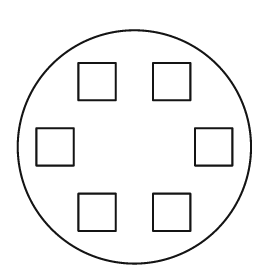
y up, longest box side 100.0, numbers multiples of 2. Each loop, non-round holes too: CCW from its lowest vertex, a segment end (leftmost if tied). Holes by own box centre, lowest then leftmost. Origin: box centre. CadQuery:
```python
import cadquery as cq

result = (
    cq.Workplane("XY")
    .moveTo(0.0, 0.0)
    .circle(50.0)
    .moveTo(-24.0, -36.0)
    .lineTo(-8.0, -36.0)
    .lineTo(-8.0, -20.0)
    .lineTo(-24.0, -20.0)
    .close()
    .moveTo(8.0, -36.0)
    .lineTo(24.0, -36.0)
    .lineTo(24.0, -20.0)
    .lineTo(8.0, -20.0)
    .close()
    .moveTo(-42.0, -8.0)
    .lineTo(-26.0, -8.0)
    .lineTo(-26.0, 8.0)
    .lineTo(-42.0, 8.0)
    .close()
    .moveTo(26.0, -8.0)
    .lineTo(42.0, -8.0)
    .lineTo(42.0, 8.0)
    .lineTo(26.0, 8.0)
    .close()
    .moveTo(-24.0, 20.0)
    .lineTo(-8.0, 20.0)
    .lineTo(-8.0, 36.0)
    .lineTo(-24.0, 36.0)
    .close()
    .moveTo(8.0, 20.0)
    .lineTo(24.0, 20.0)
    .lineTo(24.0, 36.0)
    .lineTo(8.0, 36.0)
    .close()
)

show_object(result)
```